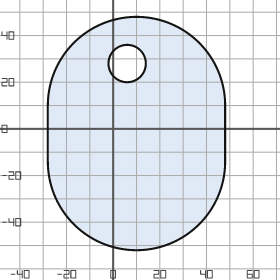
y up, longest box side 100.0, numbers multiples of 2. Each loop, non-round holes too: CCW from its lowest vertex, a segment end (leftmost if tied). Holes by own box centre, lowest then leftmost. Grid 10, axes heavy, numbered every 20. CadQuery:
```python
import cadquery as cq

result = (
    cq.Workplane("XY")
    .moveTo(-28.0, -14.0)
    .threePointArc((10.0, -52.0), (48.0, -14.0))
    .lineTo(48.0, 10.0)
    .threePointArc((10.0, 48.0), (-28.0, 10.0))
    .close()
    .moveTo(6.0, 28.0)
    .circle(8.0)
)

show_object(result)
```